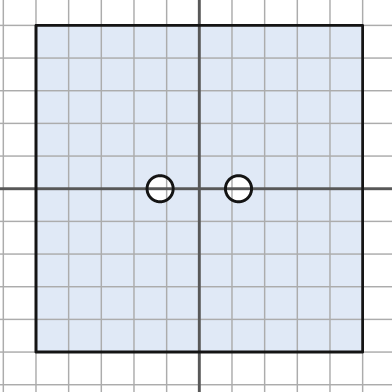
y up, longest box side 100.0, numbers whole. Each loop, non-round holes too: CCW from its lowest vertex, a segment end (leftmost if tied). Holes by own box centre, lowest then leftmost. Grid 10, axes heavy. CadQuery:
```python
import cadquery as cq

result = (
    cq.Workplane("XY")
    .moveTo(-50.0, -50.0)
    .lineTo(50.0, -50.0)
    .lineTo(50.0, 50.0)
    .lineTo(-50.0, 50.0)
    .close()
    .moveTo(-12.0, 0.0)
    .circle(4.0)
    .moveTo(12.0, 0.0)
    .circle(4.0)
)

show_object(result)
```